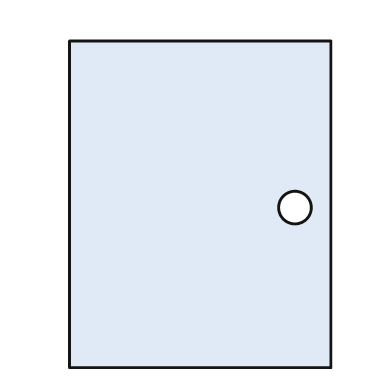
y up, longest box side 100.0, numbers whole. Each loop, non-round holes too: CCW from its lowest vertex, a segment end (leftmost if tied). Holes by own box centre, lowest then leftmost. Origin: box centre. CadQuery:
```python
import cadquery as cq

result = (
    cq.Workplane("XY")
    .moveTo(-40.0, -50.0)
    .lineTo(40.0, -50.0)
    .lineTo(40.0, 50.0)
    .lineTo(-40.0, 50.0)
    .close()
    .moveTo(29.0, -1.0)
    .circle(5.0)
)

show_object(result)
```